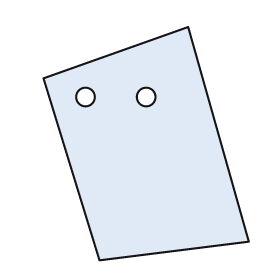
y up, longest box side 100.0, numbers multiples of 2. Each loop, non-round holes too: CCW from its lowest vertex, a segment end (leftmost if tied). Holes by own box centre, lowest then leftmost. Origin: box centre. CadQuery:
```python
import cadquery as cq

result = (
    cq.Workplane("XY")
    .moveTo(-20.0, -50.0)
    .lineTo(44.0, -42.0)
    .lineTo(18.0, 50.0)
    .lineTo(-44.0, 28.0)
    .close()
    .moveTo(-26.0, 20.0)
    .circle(4.0)
    .moveTo(0.0, 20.0)
    .circle(4.0)
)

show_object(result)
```